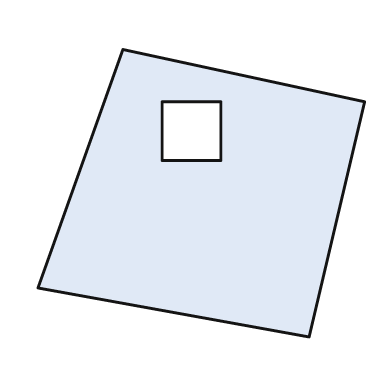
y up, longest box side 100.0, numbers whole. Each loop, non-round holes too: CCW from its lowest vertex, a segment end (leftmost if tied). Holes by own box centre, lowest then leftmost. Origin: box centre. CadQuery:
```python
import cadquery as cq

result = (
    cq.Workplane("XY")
    .moveTo(33.0, -44.0)
    .lineTo(50.0, 28.0)
    .lineTo(-24.0, 44.0)
    .lineTo(-50.0, -29.0)
    .close()
    .moveTo(-12.0, 10.0)
    .lineTo(6.0, 10.0)
    .lineTo(6.0, 28.0)
    .lineTo(-12.0, 28.0)
    .close()
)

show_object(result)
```